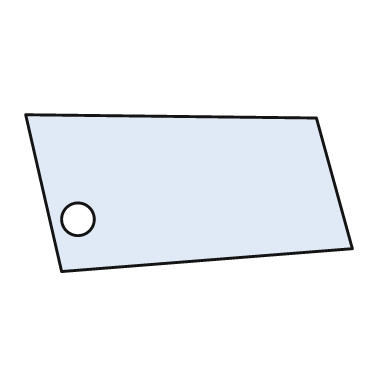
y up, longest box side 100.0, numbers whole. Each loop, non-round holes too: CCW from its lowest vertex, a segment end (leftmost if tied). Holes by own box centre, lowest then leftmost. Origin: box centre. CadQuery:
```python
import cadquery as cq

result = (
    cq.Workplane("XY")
    .moveTo(-39.0, -24.0)
    .lineTo(50.0, -17.0)
    .lineTo(39.0, 23.0)
    .lineTo(-50.0, 24.0)
    .close()
    .moveTo(-34.0, -8.0)
    .circle(5.0)
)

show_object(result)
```